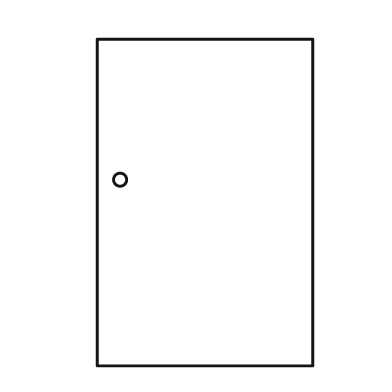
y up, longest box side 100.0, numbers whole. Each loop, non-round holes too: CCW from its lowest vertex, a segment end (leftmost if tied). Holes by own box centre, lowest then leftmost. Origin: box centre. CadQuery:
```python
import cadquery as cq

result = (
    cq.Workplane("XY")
    .moveTo(-33.0, -50.0)
    .lineTo(33.0, -50.0)
    .lineTo(33.0, 50.0)
    .lineTo(-33.0, 50.0)
    .close()
    .moveTo(-26.0, 7.0)
    .circle(2.0)
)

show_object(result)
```